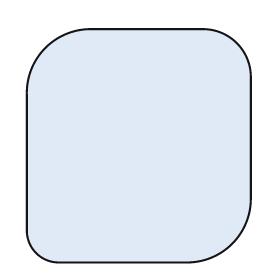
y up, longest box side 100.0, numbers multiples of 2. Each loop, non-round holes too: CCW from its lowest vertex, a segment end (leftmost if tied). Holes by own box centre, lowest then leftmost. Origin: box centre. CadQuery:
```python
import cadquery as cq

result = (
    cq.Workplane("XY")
    .moveTo(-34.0, -50.0)
    .lineTo(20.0, -50.0)
    .threePointArc((40.0, -42.0), (48.0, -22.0))
    .lineTo(48.0, 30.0)
    .threePointArc((42.0, 44.0), (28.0, 50.0))
    .lineTo(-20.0, 50.0)
    .threePointArc((-40.0, 42.0), (-48.0, 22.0))
    .lineTo(-48.0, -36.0)
    .threePointArc((-44.0, -46.0), (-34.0, -50.0))
    .close()
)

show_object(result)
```